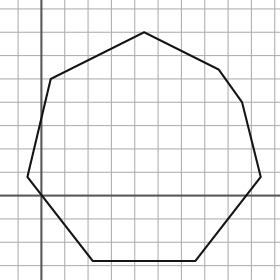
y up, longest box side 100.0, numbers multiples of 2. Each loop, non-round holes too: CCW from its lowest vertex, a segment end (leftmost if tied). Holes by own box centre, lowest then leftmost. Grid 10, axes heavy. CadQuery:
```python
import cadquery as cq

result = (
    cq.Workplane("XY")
    .moveTo(22.0, -28.0)
    .lineTo(66.0, -28.0)
    .lineTo(94.0, 8.0)
    .lineTo(86.0, 40.0)
    .lineTo(76.0, 54.0)
    .lineTo(44.0, 70.0)
    .lineTo(4.0, 50.0)
    .lineTo(-6.0, 8.0)
    .close()
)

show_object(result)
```